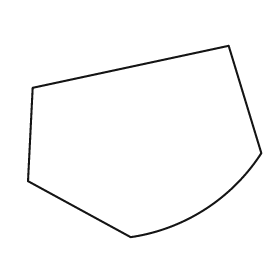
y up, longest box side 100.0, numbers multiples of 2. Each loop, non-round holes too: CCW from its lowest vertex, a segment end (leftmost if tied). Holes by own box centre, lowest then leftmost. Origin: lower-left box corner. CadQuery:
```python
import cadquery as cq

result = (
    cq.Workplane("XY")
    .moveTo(44.0, 0.0)
    .threePointArc((76.0, 12.0), (100.0, 36.0))
    .lineTo(86.0, 82.0)
    .lineTo(2.0, 64.0)
    .lineTo(0.0, 24.0)
    .close()
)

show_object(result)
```